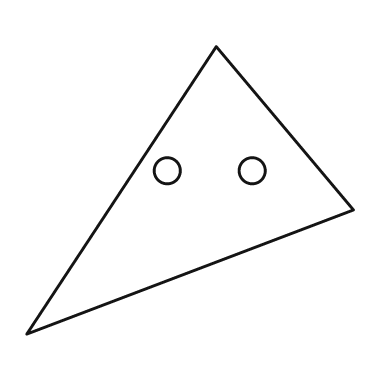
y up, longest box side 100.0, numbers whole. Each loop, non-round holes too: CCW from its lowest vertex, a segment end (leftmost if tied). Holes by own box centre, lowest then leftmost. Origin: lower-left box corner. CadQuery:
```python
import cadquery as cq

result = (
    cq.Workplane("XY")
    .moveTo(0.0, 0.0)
    .lineTo(100.0, 38.0)
    .lineTo(58.0, 88.0)
    .close()
    .moveTo(43.0, 50.0)
    .circle(4.0)
    .moveTo(69.0, 50.0)
    .circle(4.0)
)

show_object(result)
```